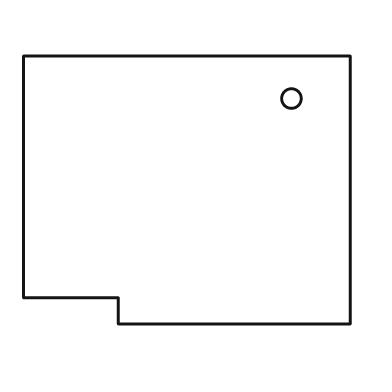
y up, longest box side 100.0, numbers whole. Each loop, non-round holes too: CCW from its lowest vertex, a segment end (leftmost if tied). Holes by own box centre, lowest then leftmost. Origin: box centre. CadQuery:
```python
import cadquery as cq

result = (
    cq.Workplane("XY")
    .moveTo(-21.0, -41.0)
    .lineTo(50.0, -41.0)
    .lineTo(50.0, 41.0)
    .lineTo(-50.0, 41.0)
    .lineTo(-50.0, -33.0)
    .lineTo(-21.0, -33.0)
    .close()
    .moveTo(32.0, 28.0)
    .circle(3.0)
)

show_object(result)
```